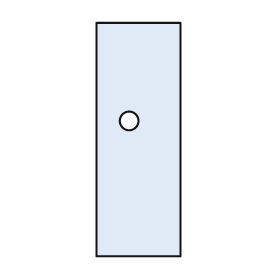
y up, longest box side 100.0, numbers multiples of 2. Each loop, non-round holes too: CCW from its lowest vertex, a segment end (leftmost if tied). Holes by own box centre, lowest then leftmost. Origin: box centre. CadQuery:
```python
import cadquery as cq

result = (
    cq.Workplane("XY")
    .moveTo(-18.0, -50.0)
    .lineTo(18.0, -50.0)
    .lineTo(18.0, 50.0)
    .lineTo(-18.0, 50.0)
    .close()
    .moveTo(-4.0, 8.0)
    .circle(4.0)
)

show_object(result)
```